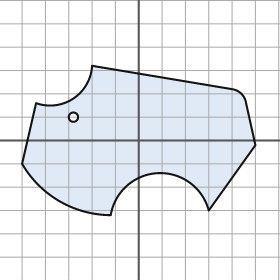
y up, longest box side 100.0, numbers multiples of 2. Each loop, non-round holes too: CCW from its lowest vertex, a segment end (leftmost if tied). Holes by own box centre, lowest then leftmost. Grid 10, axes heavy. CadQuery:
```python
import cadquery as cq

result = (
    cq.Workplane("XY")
    .moveTo(-12.0, -32.0)
    .threePointArc((8.0, -14.0), (30.0, -30.0))
    .lineTo(50.0, -2.0)
    .lineTo(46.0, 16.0)
    .threePointArc((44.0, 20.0), (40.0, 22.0))
    .lineTo(-20.0, 32.0)
    .threePointArc((-28.0, 18.0), (-44.0, 16.0))
    .lineTo(-50.0, -10.0)
    .threePointArc((-34.0, -26.0), (-12.0, -32.0))
    .close()
    .moveTo(-28.0, 10.0)
    .circle(2.0)
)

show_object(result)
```